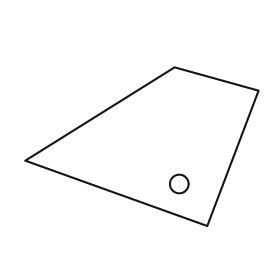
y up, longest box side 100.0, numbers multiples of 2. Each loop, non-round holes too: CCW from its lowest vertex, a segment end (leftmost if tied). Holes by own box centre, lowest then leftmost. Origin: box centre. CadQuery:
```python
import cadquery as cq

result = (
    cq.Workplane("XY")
    .moveTo(28.0, -34.0)
    .lineTo(50.0, 24.0)
    .lineTo(14.0, 34.0)
    .lineTo(-50.0, -6.0)
    .close()
    .moveTo(16.0, -16.0)
    .circle(4.0)
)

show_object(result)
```